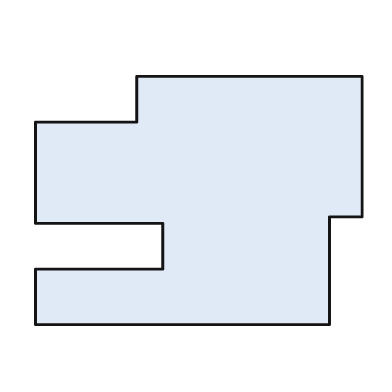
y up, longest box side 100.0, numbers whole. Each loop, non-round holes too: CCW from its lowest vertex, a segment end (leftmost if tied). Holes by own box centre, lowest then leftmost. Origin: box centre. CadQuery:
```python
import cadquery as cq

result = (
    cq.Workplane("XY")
    .moveTo(-50.0, -38.0)
    .lineTo(40.0, -38.0)
    .lineTo(40.0, -5.0)
    .lineTo(50.0, -5.0)
    .lineTo(50.0, 38.0)
    .lineTo(-19.0, 38.0)
    .lineTo(-19.0, 24.0)
    .lineTo(-50.0, 24.0)
    .lineTo(-50.0, -7.0)
    .lineTo(-11.0, -7.0)
    .lineTo(-11.0, -21.0)
    .lineTo(-50.0, -21.0)
    .close()
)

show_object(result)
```